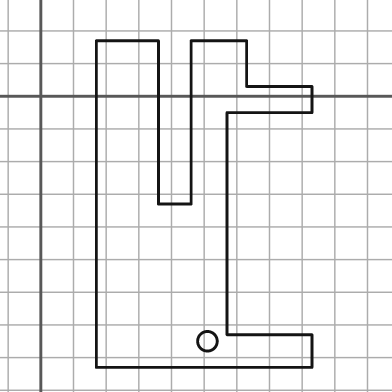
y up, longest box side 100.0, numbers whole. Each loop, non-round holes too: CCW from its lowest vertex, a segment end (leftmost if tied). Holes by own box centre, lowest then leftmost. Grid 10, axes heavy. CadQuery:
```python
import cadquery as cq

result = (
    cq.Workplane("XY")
    .moveTo(17.0, -83.0)
    .lineTo(83.0, -83.0)
    .lineTo(83.0, -73.0)
    .lineTo(57.0, -73.0)
    .lineTo(57.0, -5.0)
    .lineTo(83.0, -5.0)
    .lineTo(83.0, 3.0)
    .lineTo(63.0, 3.0)
    .lineTo(63.0, 17.0)
    .lineTo(46.0, 17.0)
    .lineTo(46.0, -33.0)
    .lineTo(36.0, -33.0)
    .lineTo(36.0, 17.0)
    .lineTo(17.0, 17.0)
    .close()
    .moveTo(51.0, -75.0)
    .circle(3.0)
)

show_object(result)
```